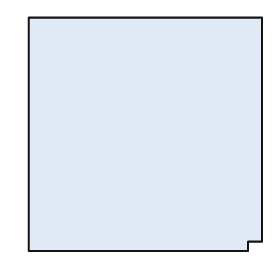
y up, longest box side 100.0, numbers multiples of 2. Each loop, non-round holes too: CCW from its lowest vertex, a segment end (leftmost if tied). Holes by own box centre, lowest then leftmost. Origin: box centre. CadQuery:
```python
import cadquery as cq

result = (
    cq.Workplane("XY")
    .moveTo(-50.0, -50.0)
    .lineTo(44.0, -50.0)
    .lineTo(44.0, -46.0)
    .lineTo(50.0, -46.0)
    .lineTo(50.0, 50.0)
    .lineTo(-50.0, 50.0)
    .close()
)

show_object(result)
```